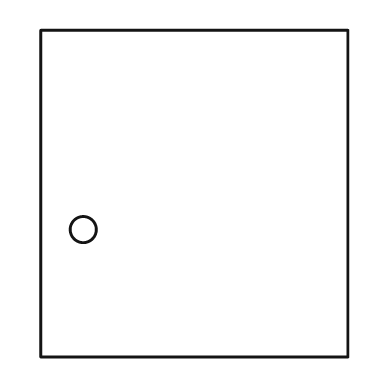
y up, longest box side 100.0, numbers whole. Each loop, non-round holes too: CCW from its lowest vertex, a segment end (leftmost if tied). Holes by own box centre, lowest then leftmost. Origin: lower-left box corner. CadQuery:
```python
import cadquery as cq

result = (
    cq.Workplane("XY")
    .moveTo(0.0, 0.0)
    .lineTo(94.0, 0.0)
    .lineTo(94.0, 100.0)
    .lineTo(0.0, 100.0)
    .close()
    .moveTo(13.0, 39.0)
    .circle(4.0)
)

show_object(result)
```